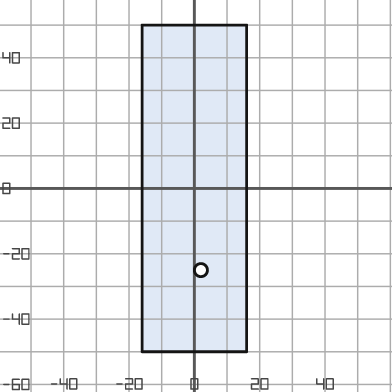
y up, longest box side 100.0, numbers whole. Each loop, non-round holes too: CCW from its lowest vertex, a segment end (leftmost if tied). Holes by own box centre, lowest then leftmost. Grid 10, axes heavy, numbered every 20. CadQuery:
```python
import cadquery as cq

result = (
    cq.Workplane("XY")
    .moveTo(-16.0, -50.0)
    .lineTo(16.0, -50.0)
    .lineTo(16.0, 50.0)
    .lineTo(-16.0, 50.0)
    .close()
    .moveTo(2.0, -25.0)
    .circle(2.0)
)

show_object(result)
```